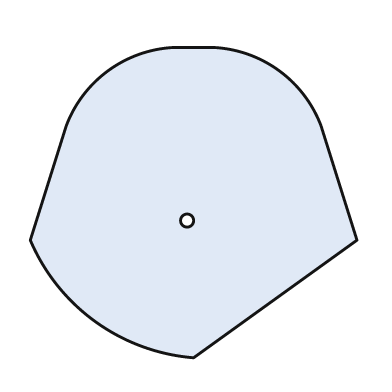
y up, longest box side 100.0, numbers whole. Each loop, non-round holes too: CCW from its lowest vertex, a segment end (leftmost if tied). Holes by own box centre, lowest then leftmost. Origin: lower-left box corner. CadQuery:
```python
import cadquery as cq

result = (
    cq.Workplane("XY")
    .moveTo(50.0, 0.0)
    .lineTo(100.0, 36.0)
    .lineTo(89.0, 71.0)
    .threePointArc((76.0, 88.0), (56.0, 95.0))
    .lineTo(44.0, 95.0)
    .threePointArc((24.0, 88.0), (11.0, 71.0))
    .lineTo(0.0, 36.0)
    .threePointArc((20.0, 11.0), (50.0, 0.0))
    .close()
    .moveTo(48.0, 42.0)
    .circle(2.0)
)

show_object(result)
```